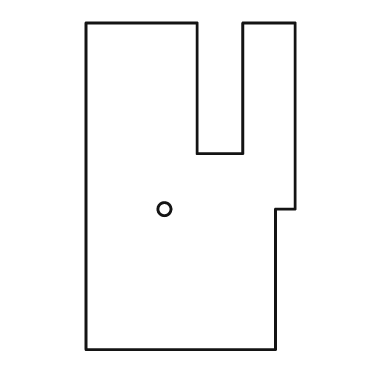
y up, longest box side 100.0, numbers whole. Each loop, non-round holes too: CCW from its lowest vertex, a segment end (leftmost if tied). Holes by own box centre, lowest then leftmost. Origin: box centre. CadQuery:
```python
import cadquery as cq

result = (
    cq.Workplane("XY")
    .moveTo(-32.0, -50.0)
    .lineTo(26.0, -50.0)
    .lineTo(26.0, -7.0)
    .lineTo(32.0, -7.0)
    .lineTo(32.0, 50.0)
    .lineTo(16.0, 50.0)
    .lineTo(16.0, 10.0)
    .lineTo(2.0, 10.0)
    .lineTo(2.0, 50.0)
    .lineTo(-32.0, 50.0)
    .close()
    .moveTo(-8.0, -7.0)
    .circle(2.0)
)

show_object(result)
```